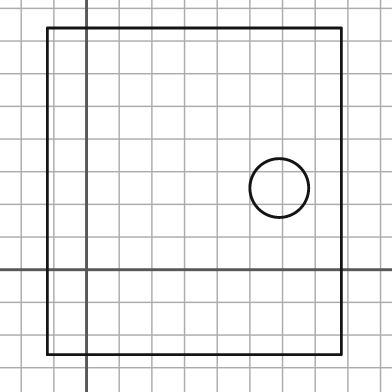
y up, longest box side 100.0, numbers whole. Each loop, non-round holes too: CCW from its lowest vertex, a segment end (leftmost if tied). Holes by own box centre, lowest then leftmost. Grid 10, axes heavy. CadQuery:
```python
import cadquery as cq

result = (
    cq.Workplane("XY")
    .moveTo(-12.0, -26.0)
    .lineTo(78.0, -26.0)
    .lineTo(78.0, 74.0)
    .lineTo(-12.0, 74.0)
    .close()
    .moveTo(59.0, 25.0)
    .circle(9.0)
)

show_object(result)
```